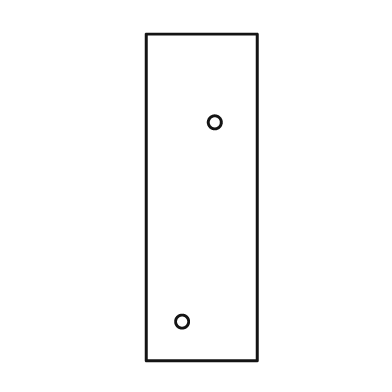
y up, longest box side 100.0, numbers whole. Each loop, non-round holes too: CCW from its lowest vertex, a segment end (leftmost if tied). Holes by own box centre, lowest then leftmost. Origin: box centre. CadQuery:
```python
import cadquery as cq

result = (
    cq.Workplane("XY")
    .moveTo(-17.0, -50.0)
    .lineTo(17.0, -50.0)
    .lineTo(17.0, 50.0)
    .lineTo(-17.0, 50.0)
    .close()
    .moveTo(-6.0, -38.0)
    .circle(2.0)
    .moveTo(4.0, 23.0)
    .circle(2.0)
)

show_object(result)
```